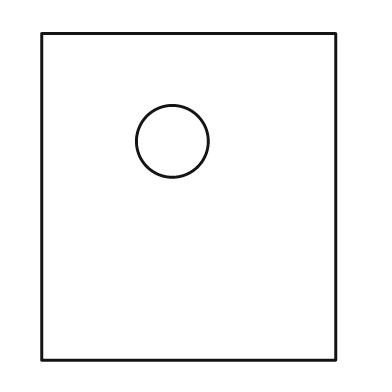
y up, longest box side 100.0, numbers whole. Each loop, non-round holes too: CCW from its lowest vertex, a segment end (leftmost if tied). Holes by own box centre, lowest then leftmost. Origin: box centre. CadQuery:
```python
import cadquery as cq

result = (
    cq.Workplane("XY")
    .moveTo(-45.0, -50.0)
    .lineTo(45.0, -50.0)
    .lineTo(45.0, 50.0)
    .lineTo(-45.0, 50.0)
    .close()
    .moveTo(-5.0, 17.0)
    .circle(11.0)
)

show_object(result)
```